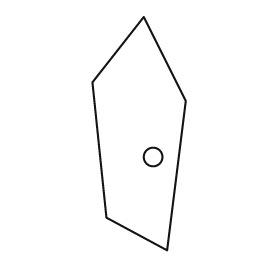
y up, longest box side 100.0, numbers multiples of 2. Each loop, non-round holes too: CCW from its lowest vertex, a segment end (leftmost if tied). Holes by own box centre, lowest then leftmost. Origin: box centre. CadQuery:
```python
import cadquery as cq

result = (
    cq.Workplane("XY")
    .moveTo(12.0, -50.0)
    .lineTo(20.0, 14.0)
    .lineTo(2.0, 50.0)
    .lineTo(-20.0, 22.0)
    .lineTo(-14.0, -36.0)
    .close()
    .moveTo(6.0, -10.0)
    .circle(4.0)
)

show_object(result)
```